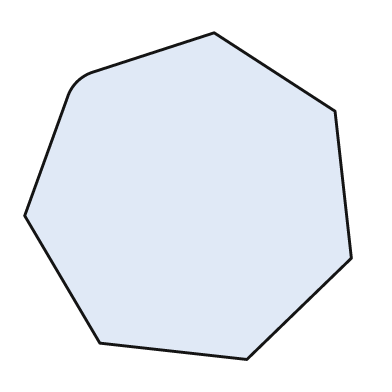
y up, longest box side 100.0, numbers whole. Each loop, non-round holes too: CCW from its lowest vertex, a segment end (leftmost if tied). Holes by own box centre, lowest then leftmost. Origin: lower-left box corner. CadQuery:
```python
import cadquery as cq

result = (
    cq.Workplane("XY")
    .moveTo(68.0, 0.0)
    .lineTo(100.0, 31.0)
    .lineTo(95.0, 76.0)
    .lineTo(58.0, 100.0)
    .lineTo(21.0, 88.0)
    .threePointArc((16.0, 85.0), (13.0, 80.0))
    .lineTo(0.0, 44.0)
    .lineTo(23.0, 5.0)
    .close()
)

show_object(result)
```